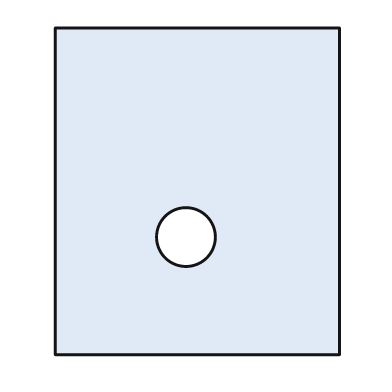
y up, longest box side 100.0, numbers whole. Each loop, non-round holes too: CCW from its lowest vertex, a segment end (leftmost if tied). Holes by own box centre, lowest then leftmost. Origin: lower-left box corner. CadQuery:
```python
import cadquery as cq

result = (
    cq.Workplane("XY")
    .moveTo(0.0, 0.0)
    .lineTo(87.0, 0.0)
    .lineTo(87.0, 100.0)
    .lineTo(0.0, 100.0)
    .close()
    .moveTo(40.0, 36.0)
    .circle(9.0)
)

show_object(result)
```